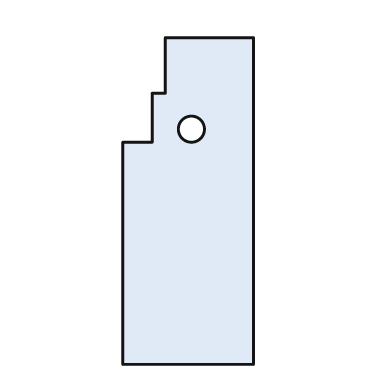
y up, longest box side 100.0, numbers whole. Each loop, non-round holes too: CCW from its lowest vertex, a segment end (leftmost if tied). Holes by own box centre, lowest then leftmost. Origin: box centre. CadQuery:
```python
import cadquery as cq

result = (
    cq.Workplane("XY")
    .moveTo(-20.0, -50.0)
    .lineTo(20.0, -50.0)
    .lineTo(20.0, 50.0)
    .lineTo(-7.0, 50.0)
    .lineTo(-7.0, 33.0)
    .lineTo(-11.0, 33.0)
    .lineTo(-11.0, 18.0)
    .lineTo(-20.0, 18.0)
    .close()
    .moveTo(1.0, 22.0)
    .circle(4.0)
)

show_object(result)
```